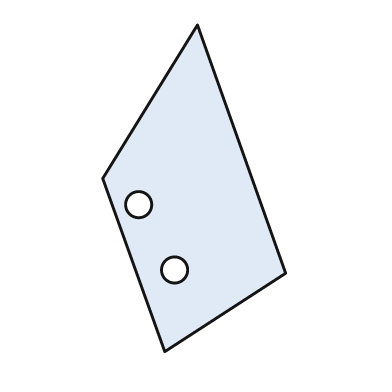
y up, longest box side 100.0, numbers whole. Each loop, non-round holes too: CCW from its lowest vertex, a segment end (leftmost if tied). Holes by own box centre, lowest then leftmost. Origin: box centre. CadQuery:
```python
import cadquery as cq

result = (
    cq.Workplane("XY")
    .moveTo(-9.0, -50.0)
    .lineTo(28.0, -26.0)
    .lineTo(1.0, 50.0)
    .lineTo(-28.0, 3.0)
    .close()
    .moveTo(-6.0, -25.0)
    .circle(4.0)
    .moveTo(-17.0, -5.0)
    .circle(4.0)
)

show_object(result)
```